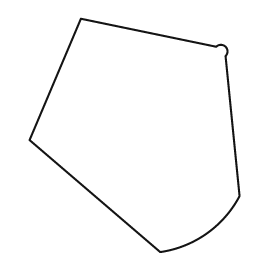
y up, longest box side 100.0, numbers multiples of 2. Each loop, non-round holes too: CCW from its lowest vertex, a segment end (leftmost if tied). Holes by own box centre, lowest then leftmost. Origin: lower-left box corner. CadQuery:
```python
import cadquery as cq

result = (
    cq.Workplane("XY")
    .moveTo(56.0, 0.0)
    .threePointArc((76.0, 8.0), (90.0, 24.0))
    .lineTo(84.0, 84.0)
    .threePointArc((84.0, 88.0), (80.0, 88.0))
    .lineTo(22.0, 100.0)
    .lineTo(0.0, 48.0)
    .close()
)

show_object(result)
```